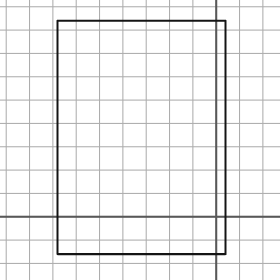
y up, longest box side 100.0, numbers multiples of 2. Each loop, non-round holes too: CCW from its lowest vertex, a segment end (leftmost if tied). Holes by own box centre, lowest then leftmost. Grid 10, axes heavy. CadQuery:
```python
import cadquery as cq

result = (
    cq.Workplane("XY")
    .moveTo(-68.0, -16.0)
    .lineTo(4.0, -16.0)
    .lineTo(4.0, 84.0)
    .lineTo(-68.0, 84.0)
    .close()
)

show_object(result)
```